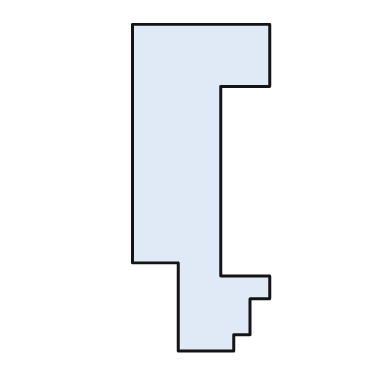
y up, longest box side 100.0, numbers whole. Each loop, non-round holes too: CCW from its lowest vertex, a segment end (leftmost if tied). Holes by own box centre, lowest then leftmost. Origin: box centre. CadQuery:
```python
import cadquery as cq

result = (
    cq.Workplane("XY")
    .moveTo(-7.0, -50.0)
    .lineTo(10.0, -50.0)
    .lineTo(10.0, -45.0)
    .lineTo(15.0, -45.0)
    .lineTo(15.0, -34.0)
    .lineTo(21.0, -34.0)
    .lineTo(21.0, -27.0)
    .lineTo(6.0, -27.0)
    .lineTo(6.0, 31.0)
    .lineTo(21.0, 31.0)
    .lineTo(21.0, 50.0)
    .lineTo(-21.0, 50.0)
    .lineTo(-21.0, -23.0)
    .lineTo(-7.0, -23.0)
    .close()
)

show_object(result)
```